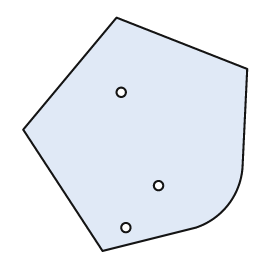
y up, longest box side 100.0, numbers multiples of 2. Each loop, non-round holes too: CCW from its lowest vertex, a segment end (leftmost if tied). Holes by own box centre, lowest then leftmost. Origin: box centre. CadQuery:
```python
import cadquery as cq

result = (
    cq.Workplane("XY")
    .moveTo(-14.0, -50.0)
    .lineTo(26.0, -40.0)
    .threePointArc((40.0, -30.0), (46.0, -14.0))
    .lineTo(48.0, 28.0)
    .lineTo(-8.0, 50.0)
    .lineTo(-48.0, 2.0)
    .close()
    .moveTo(-4.0, -40.0)
    .circle(2.0)
    .moveTo(10.0, -22.0)
    .circle(2.0)
    .moveTo(-6.0, 18.0)
    .circle(2.0)
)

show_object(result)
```